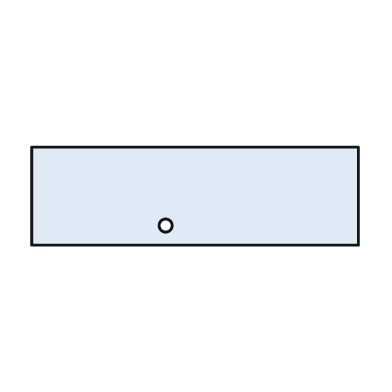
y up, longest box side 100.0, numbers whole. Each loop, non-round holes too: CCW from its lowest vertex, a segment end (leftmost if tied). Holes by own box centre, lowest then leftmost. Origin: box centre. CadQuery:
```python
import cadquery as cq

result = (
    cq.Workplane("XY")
    .moveTo(-50.0, -15.0)
    .lineTo(50.0, -15.0)
    .lineTo(50.0, 15.0)
    .lineTo(-50.0, 15.0)
    .close()
    .moveTo(-9.0, -9.0)
    .circle(2.0)
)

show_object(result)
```